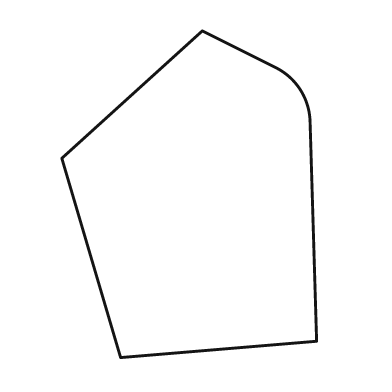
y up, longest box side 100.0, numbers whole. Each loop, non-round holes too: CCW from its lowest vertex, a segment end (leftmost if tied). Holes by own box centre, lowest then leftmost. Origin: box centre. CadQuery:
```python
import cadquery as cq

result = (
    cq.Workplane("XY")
    .moveTo(-21.0, -50.0)
    .lineTo(39.0, -45.0)
    .lineTo(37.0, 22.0)
    .threePointArc((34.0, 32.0), (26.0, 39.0))
    .lineTo(4.0, 50.0)
    .lineTo(-39.0, 11.0)
    .close()
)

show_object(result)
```